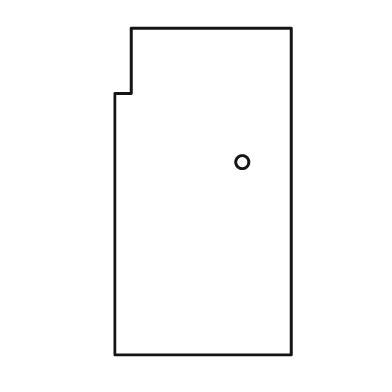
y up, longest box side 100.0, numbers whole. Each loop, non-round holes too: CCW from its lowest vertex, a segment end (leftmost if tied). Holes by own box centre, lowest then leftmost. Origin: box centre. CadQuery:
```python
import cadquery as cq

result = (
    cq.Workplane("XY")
    .moveTo(-27.0, -50.0)
    .lineTo(27.0, -50.0)
    .lineTo(27.0, 50.0)
    .lineTo(-22.0, 50.0)
    .lineTo(-22.0, 30.0)
    .lineTo(-27.0, 30.0)
    .close()
    .moveTo(12.0, 9.0)
    .circle(2.0)
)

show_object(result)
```